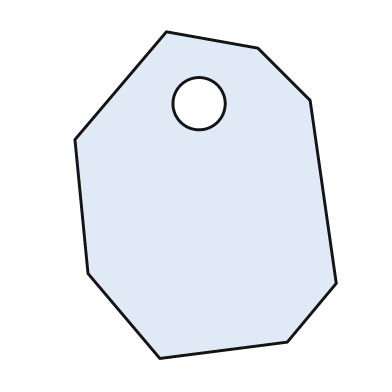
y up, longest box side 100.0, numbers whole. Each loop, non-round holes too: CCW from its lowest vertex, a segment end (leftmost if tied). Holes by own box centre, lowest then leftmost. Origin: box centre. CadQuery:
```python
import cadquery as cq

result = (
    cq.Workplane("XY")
    .moveTo(-14.0, -50.0)
    .lineTo(25.0, -45.0)
    .lineTo(40.0, -27.0)
    .lineTo(32.0, 29.0)
    .lineTo(16.0, 45.0)
    .lineTo(-12.0, 50.0)
    .lineTo(-40.0, 17.0)
    .lineTo(-36.0, -24.0)
    .close()
    .moveTo(-2.0, 28.0)
    .circle(8.0)
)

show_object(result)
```